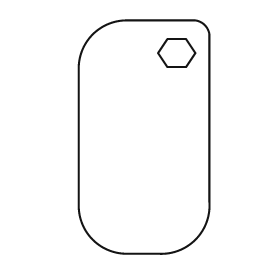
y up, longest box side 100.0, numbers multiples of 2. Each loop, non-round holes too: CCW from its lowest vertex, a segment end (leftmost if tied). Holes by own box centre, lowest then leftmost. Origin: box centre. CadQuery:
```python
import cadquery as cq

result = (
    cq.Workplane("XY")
    .moveTo(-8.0, -50.0)
    .lineTo(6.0, -50.0)
    .threePointArc((22.0, -44.0), (28.0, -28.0))
    .lineTo(28.0, 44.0)
    .threePointArc((26.0, 48.0), (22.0, 50.0))
    .lineTo(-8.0, 50.0)
    .threePointArc((-22.0, 44.0), (-28.0, 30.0))
    .lineTo(-28.0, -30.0)
    .threePointArc((-22.0, -44.0), (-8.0, -50.0))
    .close()
    .moveTo(10.0, 30.0)
    .lineTo(18.0, 30.0)
    .lineTo(22.0, 36.0)
    .lineTo(18.0, 42.0)
    .lineTo(10.0, 42.0)
    .lineTo(6.0, 36.0)
    .close()
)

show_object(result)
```